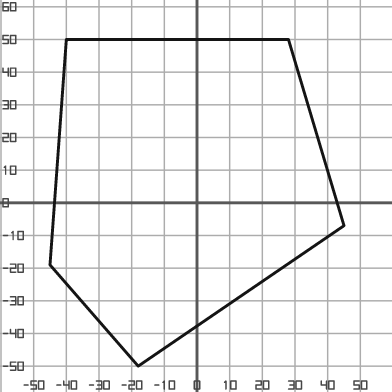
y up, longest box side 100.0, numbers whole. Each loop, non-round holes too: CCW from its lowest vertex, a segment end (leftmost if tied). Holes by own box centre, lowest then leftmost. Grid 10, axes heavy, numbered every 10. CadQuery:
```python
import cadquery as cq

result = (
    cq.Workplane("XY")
    .moveTo(-18.0, -50.0)
    .lineTo(45.0, -7.0)
    .lineTo(28.0, 50.0)
    .lineTo(-40.0, 50.0)
    .lineTo(-45.0, -19.0)
    .close()
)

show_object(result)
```